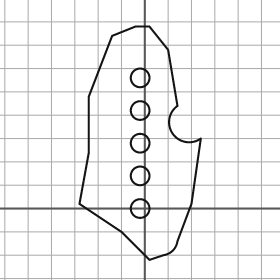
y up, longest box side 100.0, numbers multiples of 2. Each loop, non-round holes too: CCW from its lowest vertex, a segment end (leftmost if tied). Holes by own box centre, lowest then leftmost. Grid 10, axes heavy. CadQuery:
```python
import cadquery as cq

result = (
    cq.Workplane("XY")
    .moveTo(2.0, -22.0)
    .lineTo(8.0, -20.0)
    .threePointArc((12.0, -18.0), (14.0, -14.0))
    .lineTo(20.0, 2.0)
    .lineTo(24.0, 30.0)
    .threePointArc((12.0, 32.0), (14.0, 44.0))
    .lineTo(10.0, 68.0)
    .lineTo(2.0, 78.0)
    .lineTo(-4.0, 78.0)
    .lineTo(-14.0, 74.0)
    .lineTo(-24.0, 48.0)
    .lineTo(-24.0, 24.0)
    .lineTo(-28.0, 2.0)
    .lineTo(-10.0, -10.0)
    .close()
    .moveTo(-2.0, 0.0)
    .circle(4.0)
    .moveTo(-2.0, 14.0)
    .circle(4.0)
    .moveTo(-2.0, 28.0)
    .circle(4.0)
    .moveTo(-2.0, 42.0)
    .circle(4.0)
    .moveTo(-2.0, 56.0)
    .circle(4.0)
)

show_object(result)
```